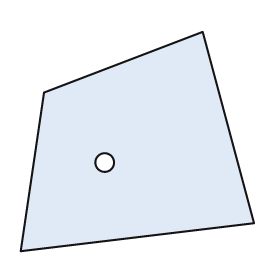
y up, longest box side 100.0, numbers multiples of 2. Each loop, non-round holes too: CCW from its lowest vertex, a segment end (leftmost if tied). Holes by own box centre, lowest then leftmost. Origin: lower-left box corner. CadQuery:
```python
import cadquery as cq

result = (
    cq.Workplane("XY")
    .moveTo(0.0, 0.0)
    .lineTo(100.0, 12.0)
    .lineTo(78.0, 94.0)
    .lineTo(10.0, 68.0)
    .close()
    .moveTo(36.0, 38.0)
    .circle(4.0)
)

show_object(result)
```